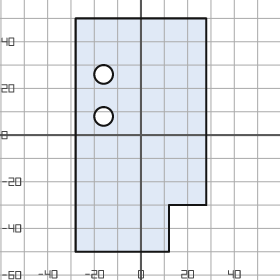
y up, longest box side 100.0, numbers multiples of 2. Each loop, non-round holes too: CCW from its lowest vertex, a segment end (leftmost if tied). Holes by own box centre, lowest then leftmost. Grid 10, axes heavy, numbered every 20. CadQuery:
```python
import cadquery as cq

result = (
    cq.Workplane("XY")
    .moveTo(-28.0, -50.0)
    .lineTo(12.0, -50.0)
    .lineTo(12.0, -30.0)
    .lineTo(28.0, -30.0)
    .lineTo(28.0, 50.0)
    .lineTo(-28.0, 50.0)
    .close()
    .moveTo(-16.0, 8.0)
    .circle(4.0)
    .moveTo(-16.0, 26.0)
    .circle(4.0)
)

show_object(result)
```